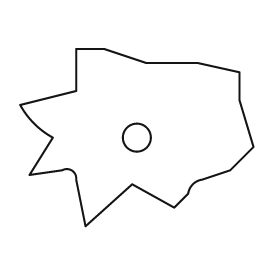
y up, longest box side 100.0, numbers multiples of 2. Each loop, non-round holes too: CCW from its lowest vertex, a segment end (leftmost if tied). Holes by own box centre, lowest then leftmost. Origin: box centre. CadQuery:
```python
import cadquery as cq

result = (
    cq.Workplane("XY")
    .moveTo(-22.0, -38.0)
    .lineTo(-2.0, -20.0)
    .lineTo(16.0, -30.0)
    .lineTo(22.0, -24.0)
    .threePointArc((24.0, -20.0), (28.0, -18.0))
    .lineTo(40.0, -14.0)
    .lineTo(50.0, -4.0)
    .lineTo(44.0, 16.0)
    .lineTo(44.0, 28.0)
    .lineTo(26.0, 32.0)
    .lineTo(4.0, 32.0)
    .lineTo(-14.0, 38.0)
    .lineTo(-26.0, 38.0)
    .lineTo(-26.0, 20.0)
    .lineTo(-50.0, 14.0)
    .threePointArc((-44.0, 6.0), (-36.0, 0.0))
    .lineTo(-46.0, -16.0)
    .lineTo(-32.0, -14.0)
    .threePointArc((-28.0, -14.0), (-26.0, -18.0))
    .close()
    .moveTo(0.0, 0.0)
    .circle(6.0)
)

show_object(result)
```